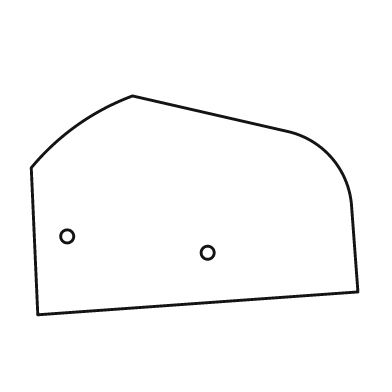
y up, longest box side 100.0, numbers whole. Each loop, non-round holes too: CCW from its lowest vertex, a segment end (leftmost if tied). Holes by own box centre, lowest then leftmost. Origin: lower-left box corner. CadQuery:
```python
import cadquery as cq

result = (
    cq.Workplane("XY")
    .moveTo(2.0, 0.0)
    .lineTo(100.0, 7.0)
    .lineTo(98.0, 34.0)
    .threePointArc((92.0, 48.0), (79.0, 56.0))
    .lineTo(31.0, 67.0)
    .threePointArc((14.0, 58.0), (0.0, 45.0))
    .close()
    .moveTo(54.0, 19.0)
    .circle(2.0)
    .moveTo(11.0, 24.0)
    .circle(2.0)
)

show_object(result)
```